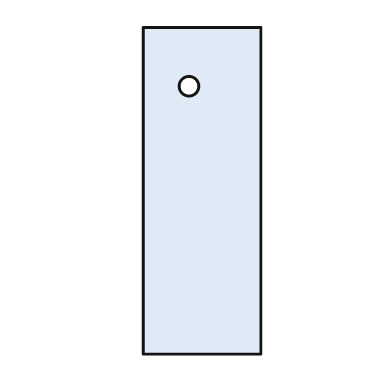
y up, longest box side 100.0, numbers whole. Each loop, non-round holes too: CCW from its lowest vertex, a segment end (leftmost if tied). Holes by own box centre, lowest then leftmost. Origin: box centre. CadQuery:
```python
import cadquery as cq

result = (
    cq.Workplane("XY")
    .moveTo(-18.0, -50.0)
    .lineTo(18.0, -50.0)
    .lineTo(18.0, 50.0)
    .lineTo(-18.0, 50.0)
    .close()
    .moveTo(-4.0, 32.0)
    .circle(3.0)
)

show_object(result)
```